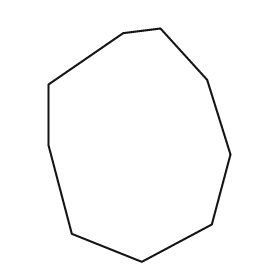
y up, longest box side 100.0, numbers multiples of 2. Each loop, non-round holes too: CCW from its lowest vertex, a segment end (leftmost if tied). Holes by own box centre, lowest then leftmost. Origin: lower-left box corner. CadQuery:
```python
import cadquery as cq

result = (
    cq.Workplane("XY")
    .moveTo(40.0, 0.0)
    .lineTo(70.0, 16.0)
    .lineTo(78.0, 46.0)
    .lineTo(68.0, 78.0)
    .lineTo(48.0, 100.0)
    .lineTo(32.0, 98.0)
    .lineTo(0.0, 76.0)
    .lineTo(0.0, 50.0)
    .lineTo(10.0, 12.0)
    .close()
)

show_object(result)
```